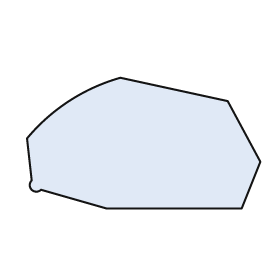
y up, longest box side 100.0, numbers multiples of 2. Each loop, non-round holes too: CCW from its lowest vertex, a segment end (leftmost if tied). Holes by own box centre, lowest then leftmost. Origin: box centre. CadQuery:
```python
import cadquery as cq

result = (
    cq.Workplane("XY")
    .moveTo(-16.0, -28.0)
    .lineTo(42.0, -28.0)
    .lineTo(50.0, -8.0)
    .lineTo(36.0, 18.0)
    .lineTo(-10.0, 28.0)
    .threePointArc((-32.0, 18.0), (-50.0, 2.0))
    .lineTo(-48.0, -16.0)
    .threePointArc((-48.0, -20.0), (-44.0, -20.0))
    .close()
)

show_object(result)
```